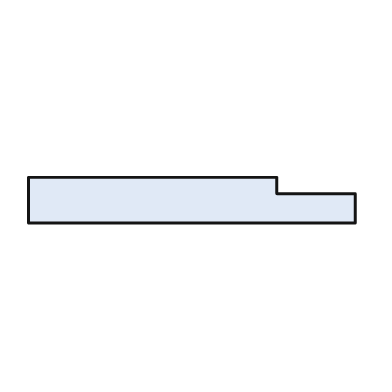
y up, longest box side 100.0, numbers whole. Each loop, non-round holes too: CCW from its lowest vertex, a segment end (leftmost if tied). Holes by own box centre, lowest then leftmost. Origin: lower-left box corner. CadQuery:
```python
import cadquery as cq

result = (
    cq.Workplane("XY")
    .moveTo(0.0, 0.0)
    .lineTo(100.0, 0.0)
    .lineTo(100.0, 9.0)
    .lineTo(76.0, 9.0)
    .lineTo(76.0, 14.0)
    .lineTo(0.0, 14.0)
    .close()
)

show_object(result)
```